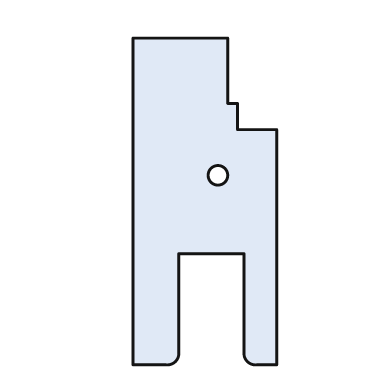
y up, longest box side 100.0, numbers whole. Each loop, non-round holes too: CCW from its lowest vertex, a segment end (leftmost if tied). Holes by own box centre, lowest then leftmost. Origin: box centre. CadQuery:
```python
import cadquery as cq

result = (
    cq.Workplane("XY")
    .moveTo(-22.0, -50.0)
    .lineTo(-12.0, -50.0)
    .threePointArc((-9.0, -49.0), (-8.0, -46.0))
    .lineTo(-8.0, -16.0)
    .lineTo(12.0, -16.0)
    .lineTo(12.0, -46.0)
    .threePointArc((13.0, -49.0), (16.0, -50.0))
    .lineTo(22.0, -50.0)
    .lineTo(22.0, 22.0)
    .lineTo(10.0, 22.0)
    .lineTo(10.0, 30.0)
    .lineTo(7.0, 30.0)
    .lineTo(7.0, 50.0)
    .lineTo(-22.0, 50.0)
    .close()
    .moveTo(4.0, 8.0)
    .circle(3.0)
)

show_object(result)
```